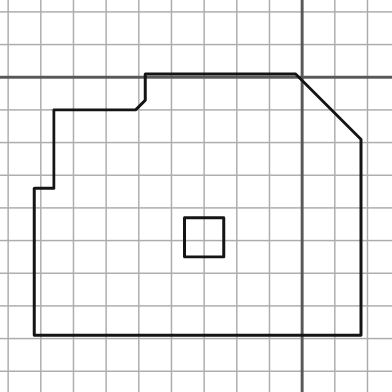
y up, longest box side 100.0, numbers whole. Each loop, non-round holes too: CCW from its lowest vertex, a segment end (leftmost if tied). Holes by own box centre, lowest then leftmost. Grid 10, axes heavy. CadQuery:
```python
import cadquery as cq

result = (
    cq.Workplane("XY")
    .moveTo(-82.0, -79.0)
    .lineTo(18.0, -79.0)
    .lineTo(18.0, -19.0)
    .lineTo(-2.0, 1.0)
    .lineTo(-48.0, 1.0)
    .lineTo(-48.0, -7.0)
    .lineTo(-51.0, -10.0)
    .lineTo(-76.0, -10.0)
    .lineTo(-76.0, -34.0)
    .lineTo(-82.0, -34.0)
    .close()
    .moveTo(-36.0, -55.0)
    .lineTo(-24.0, -55.0)
    .lineTo(-24.0, -43.0)
    .lineTo(-36.0, -43.0)
    .close()
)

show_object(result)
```